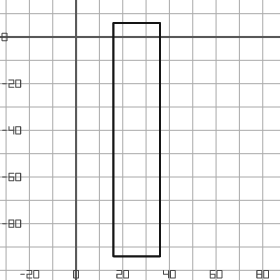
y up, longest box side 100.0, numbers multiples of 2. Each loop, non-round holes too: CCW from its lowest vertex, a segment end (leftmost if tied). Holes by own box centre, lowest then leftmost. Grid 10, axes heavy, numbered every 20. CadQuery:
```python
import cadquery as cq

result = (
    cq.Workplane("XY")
    .moveTo(16.0, -94.0)
    .lineTo(36.0, -94.0)
    .lineTo(36.0, 6.0)
    .lineTo(16.0, 6.0)
    .close()
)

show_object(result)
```